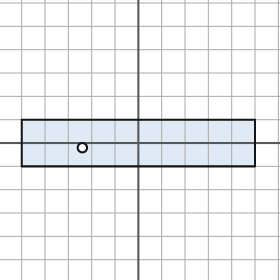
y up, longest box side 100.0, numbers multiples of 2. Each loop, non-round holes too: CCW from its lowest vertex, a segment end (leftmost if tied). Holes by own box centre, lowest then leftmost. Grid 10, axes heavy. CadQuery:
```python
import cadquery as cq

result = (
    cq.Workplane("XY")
    .moveTo(-50.0, -10.0)
    .lineTo(50.0, -10.0)
    .lineTo(50.0, 10.0)
    .lineTo(-50.0, 10.0)
    .close()
    .moveTo(-24.0, -2.0)
    .circle(2.0)
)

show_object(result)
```